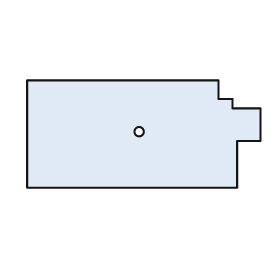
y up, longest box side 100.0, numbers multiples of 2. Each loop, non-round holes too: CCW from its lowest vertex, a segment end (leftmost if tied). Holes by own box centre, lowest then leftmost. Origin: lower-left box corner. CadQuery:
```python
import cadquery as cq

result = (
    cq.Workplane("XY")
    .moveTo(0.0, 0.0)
    .lineTo(90.0, 0.0)
    .lineTo(90.0, 20.0)
    .lineTo(100.0, 20.0)
    .lineTo(100.0, 34.0)
    .lineTo(88.0, 34.0)
    .lineTo(88.0, 38.0)
    .lineTo(82.0, 38.0)
    .lineTo(82.0, 46.0)
    .lineTo(0.0, 46.0)
    .close()
    .moveTo(48.0, 24.0)
    .circle(2.0)
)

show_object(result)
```